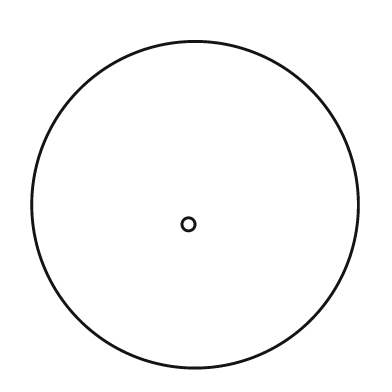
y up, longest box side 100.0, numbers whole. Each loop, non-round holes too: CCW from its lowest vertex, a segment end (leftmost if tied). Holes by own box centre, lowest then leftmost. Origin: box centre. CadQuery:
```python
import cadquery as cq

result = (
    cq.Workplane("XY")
    .moveTo(0.0, 0.0)
    .circle(50.0)
    .moveTo(-2.0, -6.0)
    .circle(2.0)
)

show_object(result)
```